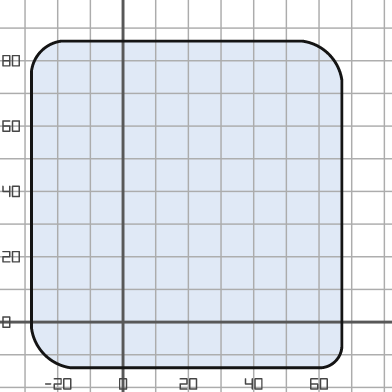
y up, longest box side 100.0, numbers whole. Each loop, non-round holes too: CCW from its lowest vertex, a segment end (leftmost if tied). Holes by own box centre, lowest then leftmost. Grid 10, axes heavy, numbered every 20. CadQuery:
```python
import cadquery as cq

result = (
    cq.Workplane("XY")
    .moveTo(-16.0, -14.0)
    .lineTo(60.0, -14.0)
    .threePointArc((65.0, -12.0), (67.0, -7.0))
    .lineTo(67.0, 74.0)
    .threePointArc((63.0, 82.0), (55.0, 86.0))
    .lineTo(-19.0, 86.0)
    .threePointArc((-25.0, 83.0), (-28.0, 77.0))
    .lineTo(-28.0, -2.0)
    .threePointArc((-24.0, -10.0), (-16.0, -14.0))
    .close()
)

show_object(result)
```